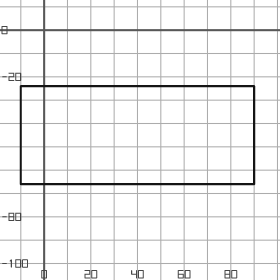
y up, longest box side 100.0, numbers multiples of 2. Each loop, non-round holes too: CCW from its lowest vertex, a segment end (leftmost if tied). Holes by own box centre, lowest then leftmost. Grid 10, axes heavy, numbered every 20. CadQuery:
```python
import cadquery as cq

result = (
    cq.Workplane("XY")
    .moveTo(-10.0, -66.0)
    .lineTo(90.0, -66.0)
    .lineTo(90.0, -24.0)
    .lineTo(-10.0, -24.0)
    .close()
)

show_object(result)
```